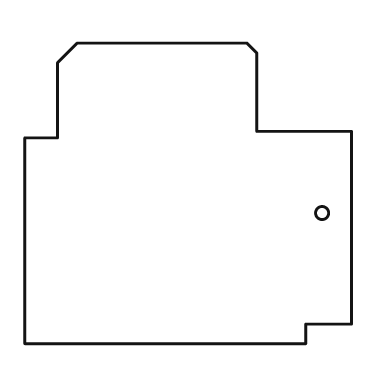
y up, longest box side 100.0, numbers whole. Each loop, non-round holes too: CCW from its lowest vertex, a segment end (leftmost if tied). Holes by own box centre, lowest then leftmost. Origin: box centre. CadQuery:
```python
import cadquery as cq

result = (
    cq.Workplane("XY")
    .moveTo(-50.0, -46.0)
    .lineTo(36.0, -46.0)
    .lineTo(36.0, -40.0)
    .lineTo(50.0, -40.0)
    .lineTo(50.0, 19.0)
    .lineTo(21.0, 19.0)
    .lineTo(21.0, 43.0)
    .lineTo(18.0, 46.0)
    .lineTo(-34.0, 46.0)
    .lineTo(-40.0, 40.0)
    .lineTo(-40.0, 17.0)
    .lineTo(-50.0, 17.0)
    .close()
    .moveTo(41.0, -6.0)
    .circle(2.0)
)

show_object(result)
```